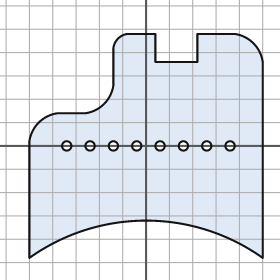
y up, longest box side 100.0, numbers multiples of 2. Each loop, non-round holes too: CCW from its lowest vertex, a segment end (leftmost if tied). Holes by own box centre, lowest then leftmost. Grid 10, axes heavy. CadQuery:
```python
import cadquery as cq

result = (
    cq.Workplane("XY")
    .moveTo(-50.0, -48.0)
    .threePointArc((0.0, -32.0), (50.0, -48.0))
    .lineTo(50.0, 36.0)
    .threePointArc((46.0, 44.0), (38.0, 48.0))
    .lineTo(22.0, 48.0)
    .lineTo(22.0, 36.0)
    .lineTo(4.0, 36.0)
    .lineTo(4.0, 48.0)
    .lineTo(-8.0, 48.0)
    .threePointArc((-12.0, 46.0), (-14.0, 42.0))
    .lineTo(-14.0, 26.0)
    .threePointArc((-18.0, 18.0), (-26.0, 14.0))
    .lineTo(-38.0, 14.0)
    .threePointArc((-46.0, 10.0), (-50.0, 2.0))
    .close()
    .moveTo(-34.0, 0.0)
    .circle(2.0)
    .moveTo(-24.0, 0.0)
    .circle(2.0)
    .moveTo(-14.0, 0.0)
    .circle(2.0)
    .moveTo(-4.0, 0.0)
    .circle(2.0)
    .moveTo(6.0, 0.0)
    .circle(2.0)
    .moveTo(16.0, 0.0)
    .circle(2.0)
    .moveTo(26.0, 0.0)
    .circle(2.0)
    .moveTo(36.0, 0.0)
    .circle(2.0)
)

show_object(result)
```